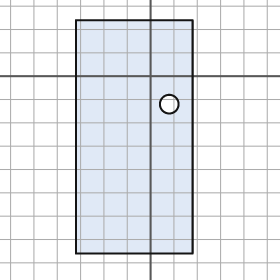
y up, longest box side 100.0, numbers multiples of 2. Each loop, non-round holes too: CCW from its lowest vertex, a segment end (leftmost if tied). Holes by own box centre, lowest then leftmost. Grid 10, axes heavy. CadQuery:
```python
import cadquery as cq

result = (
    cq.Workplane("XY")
    .moveTo(-32.0, -76.0)
    .lineTo(18.0, -76.0)
    .lineTo(18.0, 24.0)
    .lineTo(-32.0, 24.0)
    .close()
    .moveTo(8.0, -12.0)
    .circle(4.0)
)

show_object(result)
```